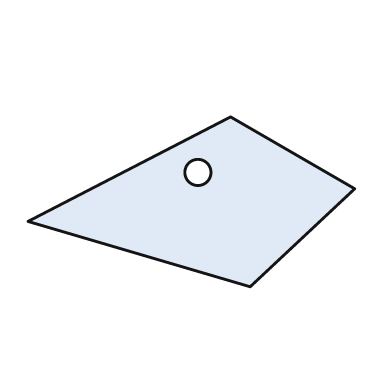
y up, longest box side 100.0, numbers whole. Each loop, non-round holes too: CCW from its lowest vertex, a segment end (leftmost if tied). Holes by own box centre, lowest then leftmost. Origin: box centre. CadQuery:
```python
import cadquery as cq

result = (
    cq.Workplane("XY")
    .moveTo(18.0, -26.0)
    .lineTo(50.0, 4.0)
    .lineTo(12.0, 26.0)
    .lineTo(-50.0, -6.0)
    .close()
    .moveTo(2.0, 9.0)
    .circle(4.0)
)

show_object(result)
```